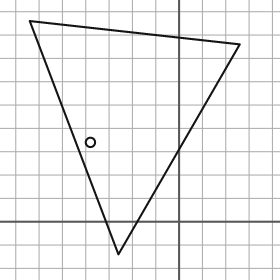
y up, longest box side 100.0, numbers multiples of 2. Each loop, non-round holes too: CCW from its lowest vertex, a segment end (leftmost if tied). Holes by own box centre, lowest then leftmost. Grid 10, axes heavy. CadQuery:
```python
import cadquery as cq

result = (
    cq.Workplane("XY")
    .moveTo(-26.0, -14.0)
    .lineTo(26.0, 76.0)
    .lineTo(-64.0, 86.0)
    .close()
    .moveTo(-38.0, 34.0)
    .circle(2.0)
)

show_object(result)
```